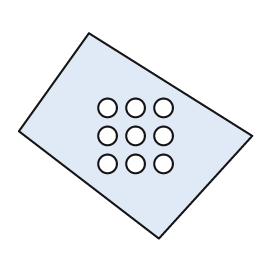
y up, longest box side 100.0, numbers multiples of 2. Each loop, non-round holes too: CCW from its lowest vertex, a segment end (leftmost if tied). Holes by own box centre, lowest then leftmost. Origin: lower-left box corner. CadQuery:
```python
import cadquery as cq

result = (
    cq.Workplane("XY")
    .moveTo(60.0, 0.0)
    .lineTo(100.0, 44.0)
    .lineTo(30.0, 88.0)
    .lineTo(0.0, 46.0)
    .close()
    .moveTo(38.0, 32.0)
    .circle(4.0)
    .moveTo(50.0, 32.0)
    .circle(4.0)
    .moveTo(62.0, 32.0)
    .circle(4.0)
    .moveTo(38.0, 44.0)
    .circle(4.0)
    .moveTo(50.0, 44.0)
    .circle(4.0)
    .moveTo(62.0, 44.0)
    .circle(4.0)
    .moveTo(38.0, 56.0)
    .circle(4.0)
    .moveTo(50.0, 56.0)
    .circle(4.0)
    .moveTo(62.0, 56.0)
    .circle(4.0)
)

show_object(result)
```